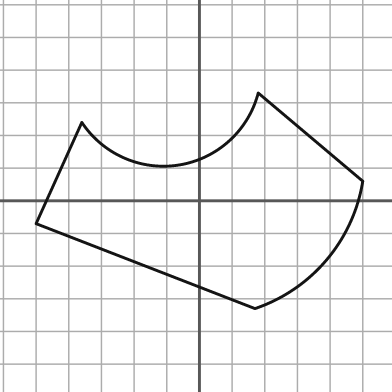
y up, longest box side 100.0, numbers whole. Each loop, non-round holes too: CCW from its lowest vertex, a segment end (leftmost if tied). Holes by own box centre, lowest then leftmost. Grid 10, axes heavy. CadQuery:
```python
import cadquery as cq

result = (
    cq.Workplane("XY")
    .moveTo(17.0, -33.0)
    .threePointArc((39.0, -18.0), (50.0, 6.0))
    .lineTo(18.0, 33.0)
    .threePointArc((-6.0, 11.0), (-36.0, 24.0))
    .lineTo(-50.0, -7.0)
    .close()
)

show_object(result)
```